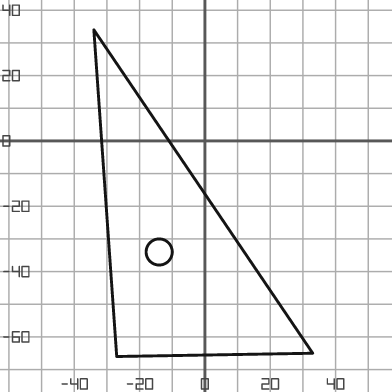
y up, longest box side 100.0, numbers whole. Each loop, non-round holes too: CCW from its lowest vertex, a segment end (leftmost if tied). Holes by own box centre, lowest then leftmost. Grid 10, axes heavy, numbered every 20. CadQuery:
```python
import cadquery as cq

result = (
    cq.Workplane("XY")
    .moveTo(-27.0, -66.0)
    .lineTo(33.0, -65.0)
    .lineTo(-34.0, 34.0)
    .close()
    .moveTo(-14.0, -34.0)
    .circle(4.0)
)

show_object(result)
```